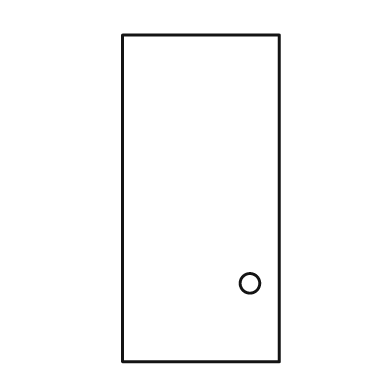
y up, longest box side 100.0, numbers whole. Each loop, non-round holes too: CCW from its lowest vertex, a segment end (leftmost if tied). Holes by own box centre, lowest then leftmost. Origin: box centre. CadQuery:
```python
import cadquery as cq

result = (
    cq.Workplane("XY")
    .moveTo(-24.0, -50.0)
    .lineTo(24.0, -50.0)
    .lineTo(24.0, 50.0)
    .lineTo(-24.0, 50.0)
    .close()
    .moveTo(15.0, -26.0)
    .circle(3.0)
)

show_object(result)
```